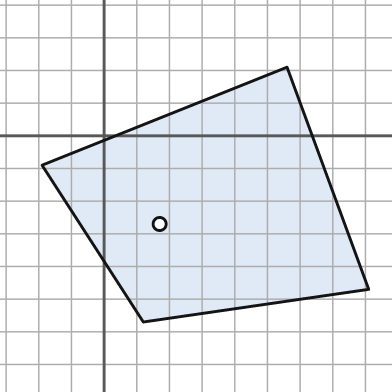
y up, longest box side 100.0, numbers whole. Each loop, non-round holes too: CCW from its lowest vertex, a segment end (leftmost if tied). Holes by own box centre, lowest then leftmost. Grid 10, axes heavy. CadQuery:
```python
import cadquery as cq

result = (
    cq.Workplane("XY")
    .moveTo(12.0, -57.0)
    .lineTo(81.0, -47.0)
    .lineTo(56.0, 21.0)
    .lineTo(-19.0, -9.0)
    .close()
    .moveTo(17.0, -27.0)
    .circle(2.0)
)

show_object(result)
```